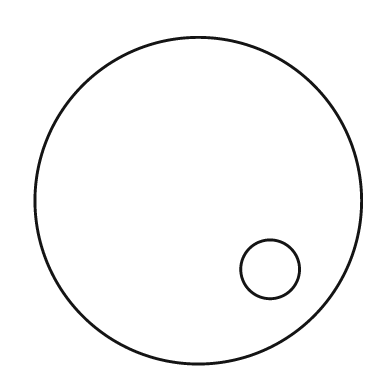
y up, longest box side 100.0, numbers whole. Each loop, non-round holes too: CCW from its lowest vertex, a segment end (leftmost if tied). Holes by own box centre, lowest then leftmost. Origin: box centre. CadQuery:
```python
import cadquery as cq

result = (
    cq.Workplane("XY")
    .moveTo(0.0, 0.0)
    .circle(50.0)
    .moveTo(22.0, -21.0)
    .circle(9.0)
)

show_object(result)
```